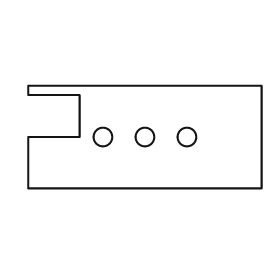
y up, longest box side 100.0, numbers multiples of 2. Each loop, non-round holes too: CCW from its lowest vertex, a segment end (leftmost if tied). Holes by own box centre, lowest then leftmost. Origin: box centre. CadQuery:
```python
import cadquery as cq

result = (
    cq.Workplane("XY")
    .moveTo(-50.0, -22.0)
    .lineTo(50.0, -22.0)
    .lineTo(50.0, 22.0)
    .lineTo(-50.0, 22.0)
    .lineTo(-50.0, 18.0)
    .lineTo(-28.0, 18.0)
    .lineTo(-28.0, 0.0)
    .lineTo(-50.0, 0.0)
    .close()
    .moveTo(-18.0, 0.0)
    .circle(4.0)
    .moveTo(0.0, 0.0)
    .circle(4.0)
    .moveTo(18.0, 0.0)
    .circle(4.0)
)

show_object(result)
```